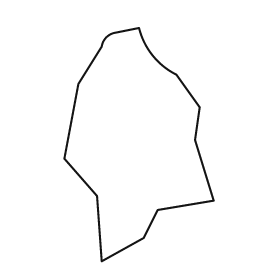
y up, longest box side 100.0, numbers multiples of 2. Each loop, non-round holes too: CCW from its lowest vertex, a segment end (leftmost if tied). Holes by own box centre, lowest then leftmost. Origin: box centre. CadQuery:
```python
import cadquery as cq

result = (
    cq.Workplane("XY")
    .moveTo(-16.0, -50.0)
    .lineTo(2.0, -40.0)
    .lineTo(8.0, -28.0)
    .lineTo(32.0, -24.0)
    .lineTo(24.0, 2.0)
    .lineTo(26.0, 16.0)
    .lineTo(16.0, 30.0)
    .threePointArc((6.0, 38.0), (0.0, 50.0))
    .lineTo(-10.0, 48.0)
    .threePointArc((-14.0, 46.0), (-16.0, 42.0))
    .lineTo(-26.0, 26.0)
    .lineTo(-32.0, -6.0)
    .lineTo(-18.0, -22.0)
    .close()
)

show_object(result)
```